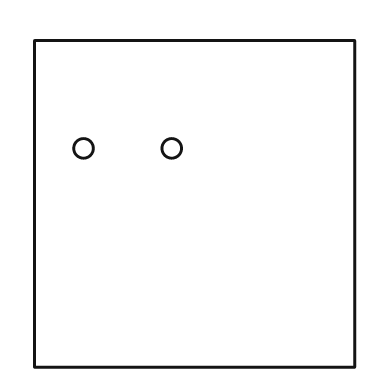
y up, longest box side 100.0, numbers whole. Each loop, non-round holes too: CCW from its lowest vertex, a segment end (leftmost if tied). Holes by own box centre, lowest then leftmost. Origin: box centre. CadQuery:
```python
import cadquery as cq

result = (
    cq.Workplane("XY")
    .moveTo(-49.0, -50.0)
    .lineTo(49.0, -50.0)
    .lineTo(49.0, 50.0)
    .lineTo(-49.0, 50.0)
    .close()
    .moveTo(-34.0, 17.0)
    .circle(3.0)
    .moveTo(-7.0, 17.0)
    .circle(3.0)
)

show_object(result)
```